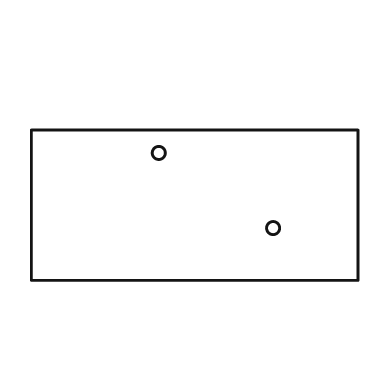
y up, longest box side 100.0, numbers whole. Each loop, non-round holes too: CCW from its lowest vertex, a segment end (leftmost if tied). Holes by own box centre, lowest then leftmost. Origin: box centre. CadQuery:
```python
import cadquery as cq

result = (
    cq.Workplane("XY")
    .moveTo(-50.0, -23.0)
    .lineTo(50.0, -23.0)
    .lineTo(50.0, 23.0)
    .lineTo(-50.0, 23.0)
    .close()
    .moveTo(24.0, -7.0)
    .circle(2.0)
    .moveTo(-11.0, 16.0)
    .circle(2.0)
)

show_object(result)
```